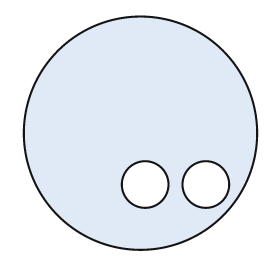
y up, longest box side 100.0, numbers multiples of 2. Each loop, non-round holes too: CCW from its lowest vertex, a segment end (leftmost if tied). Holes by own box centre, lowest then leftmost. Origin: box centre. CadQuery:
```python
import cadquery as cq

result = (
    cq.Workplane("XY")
    .moveTo(0.0, 0.0)
    .circle(50.0)
    .moveTo(2.0, -22.0)
    .circle(10.0)
    .moveTo(28.0, -22.0)
    .circle(10.0)
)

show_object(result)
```